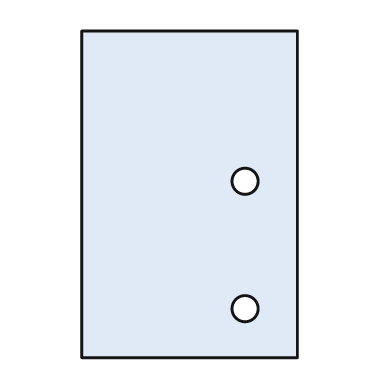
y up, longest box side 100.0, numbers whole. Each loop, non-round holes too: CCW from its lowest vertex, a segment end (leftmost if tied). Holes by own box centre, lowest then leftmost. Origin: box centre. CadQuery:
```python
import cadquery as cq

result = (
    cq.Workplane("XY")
    .moveTo(-33.0, -50.0)
    .lineTo(33.0, -50.0)
    .lineTo(33.0, 50.0)
    .lineTo(-33.0, 50.0)
    .close()
    .moveTo(17.0, -35.0)
    .circle(4.0)
    .moveTo(17.0, 4.0)
    .circle(4.0)
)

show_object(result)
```